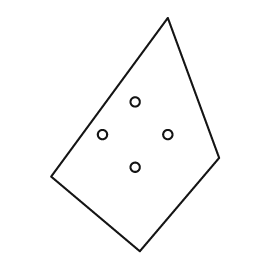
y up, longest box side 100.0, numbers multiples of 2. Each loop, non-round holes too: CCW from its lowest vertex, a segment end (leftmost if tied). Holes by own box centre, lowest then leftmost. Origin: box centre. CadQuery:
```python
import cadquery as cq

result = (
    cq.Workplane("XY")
    .moveTo(2.0, -50.0)
    .lineTo(36.0, -10.0)
    .lineTo(14.0, 50.0)
    .lineTo(-36.0, -18.0)
    .close()
    .moveTo(0.0, -14.0)
    .circle(2.0)
    .moveTo(-14.0, 0.0)
    .circle(2.0)
    .moveTo(14.0, 0.0)
    .circle(2.0)
    .moveTo(0.0, 14.0)
    .circle(2.0)
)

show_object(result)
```